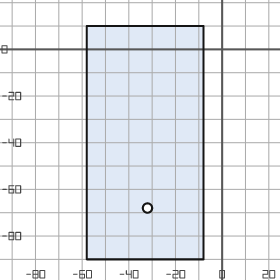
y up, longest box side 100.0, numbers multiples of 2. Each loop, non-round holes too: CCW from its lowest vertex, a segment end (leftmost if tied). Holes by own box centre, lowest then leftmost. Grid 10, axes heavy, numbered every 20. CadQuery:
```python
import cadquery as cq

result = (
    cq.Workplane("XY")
    .moveTo(-58.0, -90.0)
    .lineTo(-8.0, -90.0)
    .lineTo(-8.0, 10.0)
    .lineTo(-58.0, 10.0)
    .close()
    .moveTo(-32.0, -68.0)
    .circle(2.0)
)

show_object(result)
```